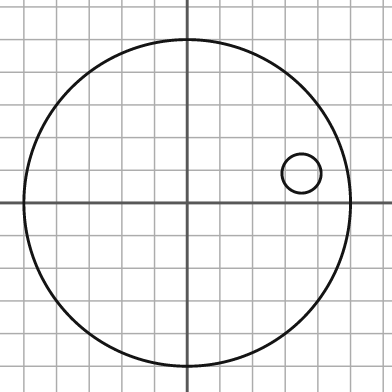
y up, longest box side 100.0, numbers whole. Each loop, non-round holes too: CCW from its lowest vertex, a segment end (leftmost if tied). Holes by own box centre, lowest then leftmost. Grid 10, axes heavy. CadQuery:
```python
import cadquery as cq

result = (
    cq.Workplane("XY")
    .moveTo(0.0, 0.0)
    .circle(50.0)
    .moveTo(35.0, 9.0)
    .circle(6.0)
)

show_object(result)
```